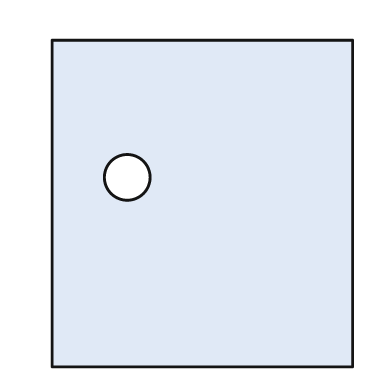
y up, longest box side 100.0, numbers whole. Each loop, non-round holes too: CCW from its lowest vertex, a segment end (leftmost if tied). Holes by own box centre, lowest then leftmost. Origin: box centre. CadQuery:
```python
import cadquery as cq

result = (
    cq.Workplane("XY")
    .moveTo(-46.0, -50.0)
    .lineTo(46.0, -50.0)
    .lineTo(46.0, 50.0)
    .lineTo(-46.0, 50.0)
    .close()
    .moveTo(-23.0, 8.0)
    .circle(7.0)
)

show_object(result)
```